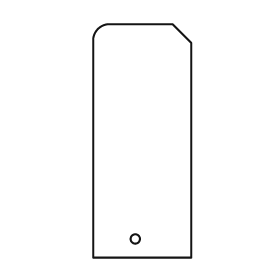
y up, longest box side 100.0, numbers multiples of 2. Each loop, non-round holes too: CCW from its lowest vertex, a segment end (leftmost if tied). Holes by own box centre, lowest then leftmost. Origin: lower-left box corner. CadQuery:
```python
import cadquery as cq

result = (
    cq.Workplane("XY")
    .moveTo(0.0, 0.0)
    .lineTo(42.0, 0.0)
    .lineTo(42.0, 92.0)
    .lineTo(34.0, 100.0)
    .lineTo(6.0, 100.0)
    .threePointArc((2.0, 98.0), (0.0, 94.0))
    .close()
    .moveTo(18.0, 8.0)
    .circle(2.0)
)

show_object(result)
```